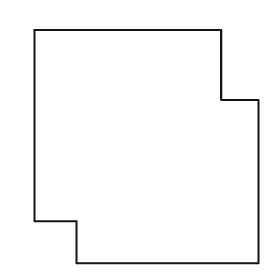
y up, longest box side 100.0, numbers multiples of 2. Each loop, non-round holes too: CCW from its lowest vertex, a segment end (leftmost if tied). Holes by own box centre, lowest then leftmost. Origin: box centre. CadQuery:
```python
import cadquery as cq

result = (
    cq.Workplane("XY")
    .moveTo(-30.0, -50.0)
    .lineTo(48.0, -50.0)
    .lineTo(48.0, 20.0)
    .lineTo(32.0, 20.0)
    .lineTo(32.0, 50.0)
    .lineTo(-48.0, 50.0)
    .lineTo(-48.0, -32.0)
    .lineTo(-30.0, -32.0)
    .close()
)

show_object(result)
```